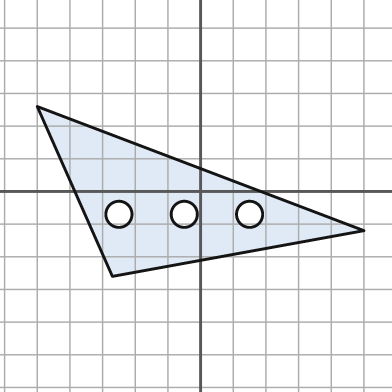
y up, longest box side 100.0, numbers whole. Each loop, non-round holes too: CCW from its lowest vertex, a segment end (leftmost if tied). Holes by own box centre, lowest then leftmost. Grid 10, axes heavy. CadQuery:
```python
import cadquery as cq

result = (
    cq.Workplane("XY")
    .moveTo(-27.0, -26.0)
    .lineTo(50.0, -12.0)
    .lineTo(-50.0, 26.0)
    .close()
    .moveTo(-25.0, -7.0)
    .circle(4.0)
    .moveTo(-5.0, -7.0)
    .circle(4.0)
    .moveTo(15.0, -7.0)
    .circle(4.0)
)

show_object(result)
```